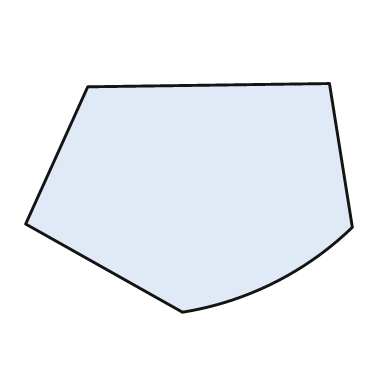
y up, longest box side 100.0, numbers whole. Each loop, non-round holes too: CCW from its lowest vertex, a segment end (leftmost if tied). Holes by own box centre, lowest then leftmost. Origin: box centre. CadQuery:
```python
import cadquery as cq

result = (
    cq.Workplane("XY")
    .moveTo(-2.0, -35.0)
    .threePointArc((26.0, -26.0), (50.0, -9.0))
    .lineTo(43.0, 35.0)
    .lineTo(-31.0, 34.0)
    .lineTo(-50.0, -8.0)
    .close()
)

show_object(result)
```